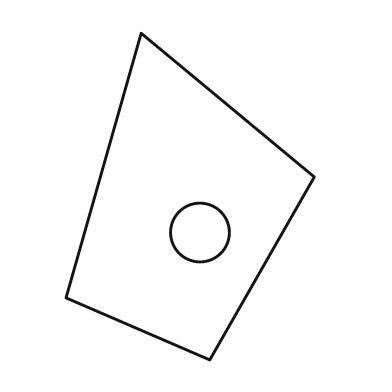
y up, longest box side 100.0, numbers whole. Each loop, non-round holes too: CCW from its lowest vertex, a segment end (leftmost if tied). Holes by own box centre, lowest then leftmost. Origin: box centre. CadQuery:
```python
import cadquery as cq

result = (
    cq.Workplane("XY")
    .moveTo(6.0, -50.0)
    .lineTo(38.0, 6.0)
    .lineTo(-15.0, 50.0)
    .lineTo(-38.0, -31.0)
    .close()
    .moveTo(3.0, -11.0)
    .circle(9.0)
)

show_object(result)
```